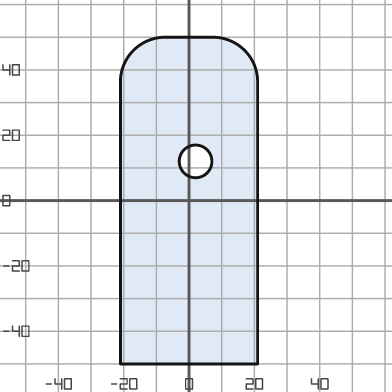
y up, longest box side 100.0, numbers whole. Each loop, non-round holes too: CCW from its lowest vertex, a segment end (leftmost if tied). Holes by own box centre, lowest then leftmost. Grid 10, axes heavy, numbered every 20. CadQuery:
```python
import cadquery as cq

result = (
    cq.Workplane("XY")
    .moveTo(-21.0, -50.0)
    .lineTo(21.0, -50.0)
    .lineTo(21.0, 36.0)
    .threePointArc((17.0, 46.0), (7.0, 50.0))
    .lineTo(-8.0, 50.0)
    .threePointArc((-17.0, 46.0), (-21.0, 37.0))
    .close()
    .moveTo(2.0, 12.0)
    .circle(5.0)
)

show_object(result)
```